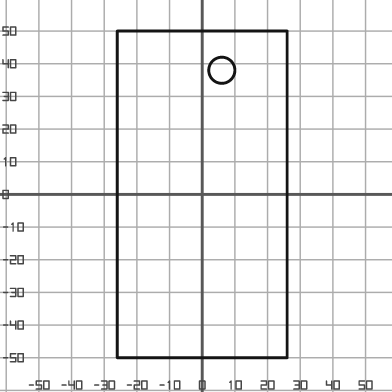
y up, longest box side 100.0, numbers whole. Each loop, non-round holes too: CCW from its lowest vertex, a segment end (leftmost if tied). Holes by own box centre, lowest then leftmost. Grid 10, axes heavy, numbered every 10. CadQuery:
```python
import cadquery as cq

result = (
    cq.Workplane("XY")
    .moveTo(-26.0, -50.0)
    .lineTo(26.0, -50.0)
    .lineTo(26.0, 50.0)
    .lineTo(-26.0, 50.0)
    .close()
    .moveTo(6.0, 38.0)
    .circle(4.0)
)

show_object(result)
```